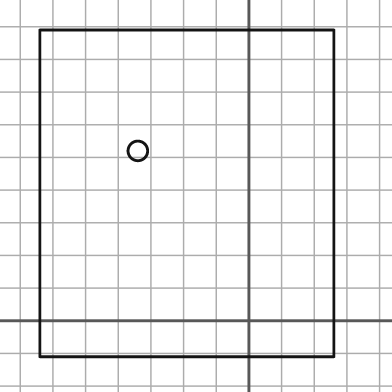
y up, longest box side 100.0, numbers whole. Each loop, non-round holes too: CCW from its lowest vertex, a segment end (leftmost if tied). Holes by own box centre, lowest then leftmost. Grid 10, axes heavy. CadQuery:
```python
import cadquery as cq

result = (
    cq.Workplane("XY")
    .moveTo(-64.0, -11.0)
    .lineTo(26.0, -11.0)
    .lineTo(26.0, 89.0)
    .lineTo(-64.0, 89.0)
    .close()
    .moveTo(-34.0, 52.0)
    .circle(3.0)
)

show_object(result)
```